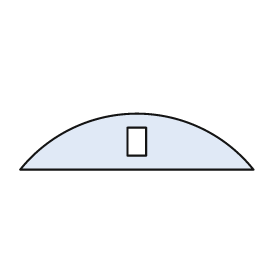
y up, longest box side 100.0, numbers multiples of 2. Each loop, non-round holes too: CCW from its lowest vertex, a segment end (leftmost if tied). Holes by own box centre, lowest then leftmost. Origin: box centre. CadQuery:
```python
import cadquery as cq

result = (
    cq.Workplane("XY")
    .moveTo(-50.0, -12.0)
    .lineTo(50.0, -12.0)
    .threePointArc((0.0, 12.0), (-50.0, -12.0))
    .close()
    .moveTo(-4.0, -6.0)
    .lineTo(4.0, -6.0)
    .lineTo(4.0, 6.0)
    .lineTo(-4.0, 6.0)
    .close()
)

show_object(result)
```